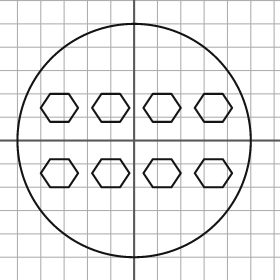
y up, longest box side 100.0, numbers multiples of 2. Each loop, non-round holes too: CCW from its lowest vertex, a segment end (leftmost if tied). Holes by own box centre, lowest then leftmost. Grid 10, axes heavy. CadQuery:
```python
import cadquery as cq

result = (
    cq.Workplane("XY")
    .moveTo(0.0, 0.0)
    .circle(50.0)
    .moveTo(-36.0, -20.0)
    .lineTo(-28.0, -20.0)
    .lineTo(-24.0, -14.0)
    .lineTo(-28.0, -8.0)
    .lineTo(-36.0, -8.0)
    .lineTo(-40.0, -14.0)
    .close()
    .moveTo(-14.0, -20.0)
    .lineTo(-6.0, -20.0)
    .lineTo(-2.0, -14.0)
    .lineTo(-6.0, -8.0)
    .lineTo(-14.0, -8.0)
    .lineTo(-18.0, -14.0)
    .close()
    .moveTo(8.0, -20.0)
    .lineTo(16.0, -20.0)
    .lineTo(20.0, -14.0)
    .lineTo(16.0, -8.0)
    .lineTo(8.0, -8.0)
    .lineTo(4.0, -14.0)
    .close()
    .moveTo(30.0, -20.0)
    .lineTo(38.0, -20.0)
    .lineTo(42.0, -14.0)
    .lineTo(38.0, -8.0)
    .lineTo(30.0, -8.0)
    .lineTo(26.0, -14.0)
    .close()
    .moveTo(-36.0, 8.0)
    .lineTo(-28.0, 8.0)
    .lineTo(-24.0, 14.0)
    .lineTo(-28.0, 20.0)
    .lineTo(-36.0, 20.0)
    .lineTo(-40.0, 14.0)
    .close()
    .moveTo(-14.0, 8.0)
    .lineTo(-6.0, 8.0)
    .lineTo(-2.0, 14.0)
    .lineTo(-6.0, 20.0)
    .lineTo(-14.0, 20.0)
    .lineTo(-18.0, 14.0)
    .close()
    .moveTo(8.0, 8.0)
    .lineTo(16.0, 8.0)
    .lineTo(20.0, 14.0)
    .lineTo(16.0, 20.0)
    .lineTo(8.0, 20.0)
    .lineTo(4.0, 14.0)
    .close()
    .moveTo(30.0, 8.0)
    .lineTo(38.0, 8.0)
    .lineTo(42.0, 14.0)
    .lineTo(38.0, 20.0)
    .lineTo(30.0, 20.0)
    .lineTo(26.0, 14.0)
    .close()
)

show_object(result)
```